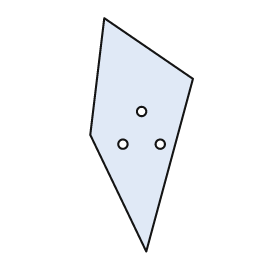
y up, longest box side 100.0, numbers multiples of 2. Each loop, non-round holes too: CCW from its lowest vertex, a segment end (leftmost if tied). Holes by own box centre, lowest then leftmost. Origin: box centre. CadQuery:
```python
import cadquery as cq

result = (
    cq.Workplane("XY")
    .moveTo(2.0, -50.0)
    .lineTo(22.0, 24.0)
    .lineTo(-16.0, 50.0)
    .lineTo(-22.0, 0.0)
    .close()
    .moveTo(-8.0, -4.0)
    .circle(2.0)
    .moveTo(8.0, -4.0)
    .circle(2.0)
    .moveTo(0.0, 10.0)
    .circle(2.0)
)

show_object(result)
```